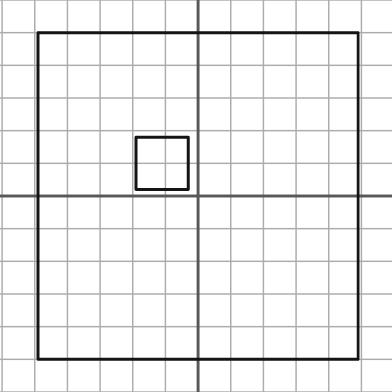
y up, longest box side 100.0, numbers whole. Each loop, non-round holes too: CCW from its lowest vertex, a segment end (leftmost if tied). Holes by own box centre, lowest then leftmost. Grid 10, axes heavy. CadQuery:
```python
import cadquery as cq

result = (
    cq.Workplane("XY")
    .moveTo(-49.0, -50.0)
    .lineTo(49.0, -50.0)
    .lineTo(49.0, 50.0)
    .lineTo(-49.0, 50.0)
    .close()
    .moveTo(-19.0, 2.0)
    .lineTo(-3.0, 2.0)
    .lineTo(-3.0, 18.0)
    .lineTo(-19.0, 18.0)
    .close()
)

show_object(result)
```